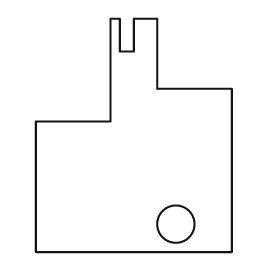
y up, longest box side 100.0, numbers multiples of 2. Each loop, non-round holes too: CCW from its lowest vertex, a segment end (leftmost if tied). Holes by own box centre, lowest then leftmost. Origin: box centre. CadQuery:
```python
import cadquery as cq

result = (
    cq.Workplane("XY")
    .moveTo(-42.0, -50.0)
    .lineTo(42.0, -50.0)
    .lineTo(42.0, 20.0)
    .lineTo(10.0, 20.0)
    .lineTo(10.0, 50.0)
    .lineTo(0.0, 50.0)
    .lineTo(0.0, 36.0)
    .lineTo(-6.0, 36.0)
    .lineTo(-6.0, 50.0)
    .lineTo(-10.0, 50.0)
    .lineTo(-10.0, 6.0)
    .lineTo(-42.0, 6.0)
    .close()
    .moveTo(18.0, -38.0)
    .circle(8.0)
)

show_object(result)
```